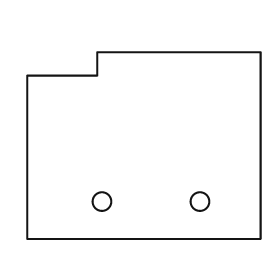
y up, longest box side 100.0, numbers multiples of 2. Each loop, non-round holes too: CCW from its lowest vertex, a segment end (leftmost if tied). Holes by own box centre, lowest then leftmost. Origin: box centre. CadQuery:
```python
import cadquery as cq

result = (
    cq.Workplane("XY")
    .moveTo(-50.0, -40.0)
    .lineTo(50.0, -40.0)
    .lineTo(50.0, 40.0)
    .lineTo(-20.0, 40.0)
    .lineTo(-20.0, 30.0)
    .lineTo(-50.0, 30.0)
    .close()
    .moveTo(-18.0, -24.0)
    .circle(4.0)
    .moveTo(24.0, -24.0)
    .circle(4.0)
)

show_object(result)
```